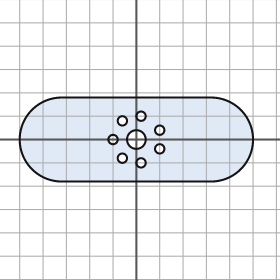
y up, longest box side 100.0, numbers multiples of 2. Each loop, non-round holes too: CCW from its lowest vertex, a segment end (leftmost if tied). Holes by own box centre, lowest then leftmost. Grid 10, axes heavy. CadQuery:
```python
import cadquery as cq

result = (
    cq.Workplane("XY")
    .moveTo(-32.0, -18.0)
    .lineTo(32.0, -18.0)
    .threePointArc((50.0, 0.0), (32.0, 18.0))
    .lineTo(-32.0, 18.0)
    .threePointArc((-50.0, 0.0), (-32.0, -18.0))
    .close()
    .moveTo(2.0, -10.0)
    .circle(2.0)
    .moveTo(-6.0, -8.0)
    .circle(2.0)
    .moveTo(10.0, -4.0)
    .circle(2.0)
    .moveTo(-10.0, 0.0)
    .circle(2.0)
    .moveTo(0.0, 0.0)
    .circle(4.0)
    .moveTo(10.0, 4.0)
    .circle(2.0)
    .moveTo(-6.0, 8.0)
    .circle(2.0)
    .moveTo(2.0, 10.0)
    .circle(2.0)
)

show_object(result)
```